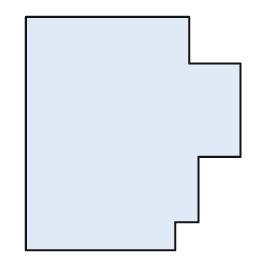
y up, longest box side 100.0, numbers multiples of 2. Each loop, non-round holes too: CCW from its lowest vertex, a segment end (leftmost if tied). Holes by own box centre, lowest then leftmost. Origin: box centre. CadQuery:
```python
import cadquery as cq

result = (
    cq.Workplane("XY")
    .moveTo(-46.0, -50.0)
    .lineTo(18.0, -50.0)
    .lineTo(18.0, -38.0)
    .lineTo(28.0, -38.0)
    .lineTo(28.0, -10.0)
    .lineTo(46.0, -10.0)
    .lineTo(46.0, 30.0)
    .lineTo(24.0, 30.0)
    .lineTo(24.0, 50.0)
    .lineTo(-46.0, 50.0)
    .close()
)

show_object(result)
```